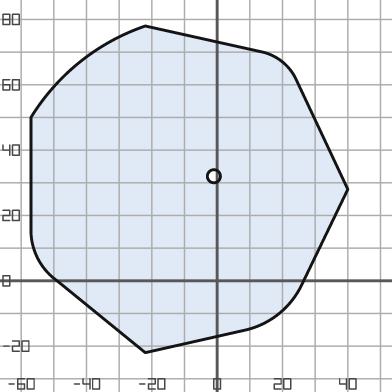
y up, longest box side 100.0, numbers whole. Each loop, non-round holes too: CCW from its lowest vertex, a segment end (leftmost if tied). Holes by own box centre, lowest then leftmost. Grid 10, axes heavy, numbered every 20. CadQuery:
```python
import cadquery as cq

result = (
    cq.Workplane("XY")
    .moveTo(-22.0, -22.0)
    .lineTo(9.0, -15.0)
    .threePointArc((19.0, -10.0), (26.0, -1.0))
    .lineTo(40.0, 28.0)
    .lineTo(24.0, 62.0)
    .threePointArc((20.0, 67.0), (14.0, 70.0))
    .lineTo(-22.0, 78.0)
    .threePointArc((-42.0, 67.0), (-57.0, 50.0))
    .lineTo(-57.0, 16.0)
    .threePointArc((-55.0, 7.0), (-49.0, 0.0))
    .close()
    .moveTo(-1.0, 32.0)
    .circle(2.0)
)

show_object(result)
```